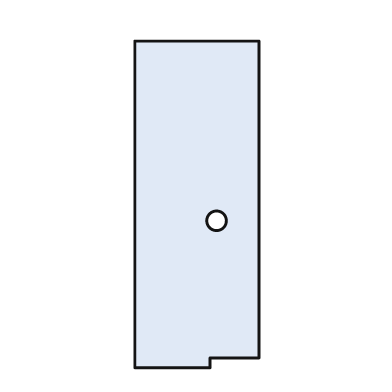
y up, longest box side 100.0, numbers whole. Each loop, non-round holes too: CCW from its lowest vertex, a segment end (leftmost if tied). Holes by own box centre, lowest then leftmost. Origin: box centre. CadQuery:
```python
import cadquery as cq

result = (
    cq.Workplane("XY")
    .moveTo(-19.0, -50.0)
    .lineTo(4.0, -50.0)
    .lineTo(4.0, -47.0)
    .lineTo(19.0, -47.0)
    .lineTo(19.0, 50.0)
    .lineTo(-19.0, 50.0)
    .close()
    .moveTo(6.0, -5.0)
    .circle(3.0)
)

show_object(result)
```